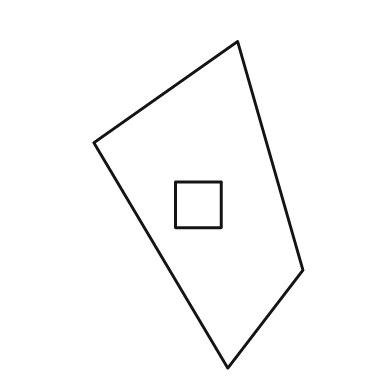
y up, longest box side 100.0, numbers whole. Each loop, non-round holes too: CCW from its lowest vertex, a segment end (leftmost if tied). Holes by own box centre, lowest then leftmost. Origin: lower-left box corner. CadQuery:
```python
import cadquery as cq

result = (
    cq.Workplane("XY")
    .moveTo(41.0, 0.0)
    .lineTo(64.0, 30.0)
    .lineTo(44.0, 100.0)
    .lineTo(0.0, 69.0)
    .close()
    .moveTo(25.0, 43.0)
    .lineTo(39.0, 43.0)
    .lineTo(39.0, 57.0)
    .lineTo(25.0, 57.0)
    .close()
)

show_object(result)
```